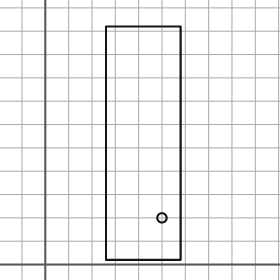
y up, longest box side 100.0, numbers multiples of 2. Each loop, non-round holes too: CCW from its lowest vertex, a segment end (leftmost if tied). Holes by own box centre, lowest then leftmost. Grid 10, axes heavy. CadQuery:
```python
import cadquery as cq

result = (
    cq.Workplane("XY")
    .moveTo(26.0, 2.0)
    .lineTo(58.0, 2.0)
    .lineTo(58.0, 102.0)
    .lineTo(26.0, 102.0)
    .close()
    .moveTo(50.0, 20.0)
    .circle(2.0)
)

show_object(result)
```